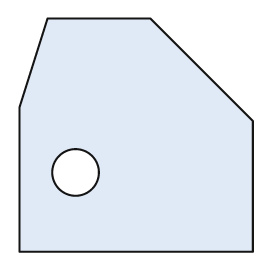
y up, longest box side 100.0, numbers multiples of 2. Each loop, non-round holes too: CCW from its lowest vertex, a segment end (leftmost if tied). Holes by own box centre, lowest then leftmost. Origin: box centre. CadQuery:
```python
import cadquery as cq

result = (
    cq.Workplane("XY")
    .moveTo(-50.0, -50.0)
    .lineTo(50.0, -50.0)
    .lineTo(50.0, 6.0)
    .lineTo(6.0, 50.0)
    .lineTo(-38.0, 50.0)
    .lineTo(-50.0, 12.0)
    .close()
    .moveTo(-26.0, -16.0)
    .circle(10.0)
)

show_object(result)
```